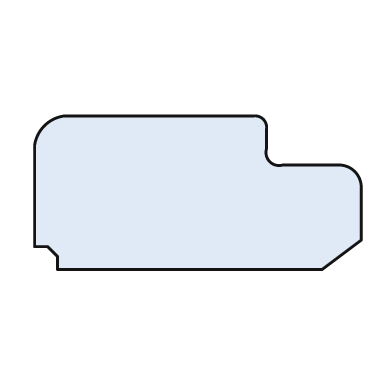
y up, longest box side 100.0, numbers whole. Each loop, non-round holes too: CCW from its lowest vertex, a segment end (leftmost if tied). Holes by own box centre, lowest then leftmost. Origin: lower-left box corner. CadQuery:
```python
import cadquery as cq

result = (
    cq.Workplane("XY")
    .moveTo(7.0, 0.0)
    .lineTo(88.0, 0.0)
    .lineTo(100.0, 9.0)
    .lineTo(100.0, 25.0)
    .threePointArc((98.0, 30.0), (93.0, 32.0))
    .lineTo(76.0, 32.0)
    .threePointArc((72.0, 33.0), (71.0, 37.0))
    .lineTo(71.0, 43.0)
    .threePointArc((70.0, 46.0), (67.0, 47.0))
    .lineTo(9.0, 47.0)
    .threePointArc((3.0, 44.0), (0.0, 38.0))
    .lineTo(0.0, 7.0)
    .lineTo(4.0, 7.0)
    .lineTo(7.0, 4.0)
    .close()
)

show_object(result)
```